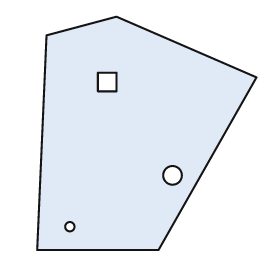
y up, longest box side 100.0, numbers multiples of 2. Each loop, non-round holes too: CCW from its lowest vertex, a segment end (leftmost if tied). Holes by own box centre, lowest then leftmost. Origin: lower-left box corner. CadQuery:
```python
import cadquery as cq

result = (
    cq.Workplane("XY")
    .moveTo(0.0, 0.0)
    .lineTo(52.0, 0.0)
    .lineTo(94.0, 74.0)
    .lineTo(34.0, 100.0)
    .lineTo(4.0, 92.0)
    .close()
    .moveTo(14.0, 10.0)
    .circle(2.0)
    .moveTo(58.0, 32.0)
    .circle(4.0)
    .moveTo(26.0, 68.0)
    .lineTo(34.0, 68.0)
    .lineTo(34.0, 76.0)
    .lineTo(26.0, 76.0)
    .close()
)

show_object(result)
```